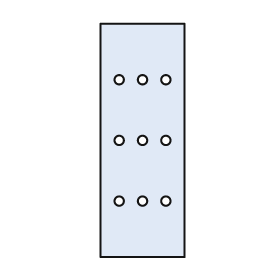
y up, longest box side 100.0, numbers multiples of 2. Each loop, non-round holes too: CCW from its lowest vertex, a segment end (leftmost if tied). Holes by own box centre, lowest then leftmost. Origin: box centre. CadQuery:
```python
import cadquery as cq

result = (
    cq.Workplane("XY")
    .moveTo(-18.0, -50.0)
    .lineTo(18.0, -50.0)
    .lineTo(18.0, 50.0)
    .lineTo(-18.0, 50.0)
    .close()
    .moveTo(-10.0, -26.0)
    .circle(2.0)
    .moveTo(0.0, -26.0)
    .circle(2.0)
    .moveTo(10.0, -26.0)
    .circle(2.0)
    .moveTo(-10.0, 0.0)
    .circle(2.0)
    .moveTo(0.0, 0.0)
    .circle(2.0)
    .moveTo(10.0, 0.0)
    .circle(2.0)
    .moveTo(-10.0, 26.0)
    .circle(2.0)
    .moveTo(0.0, 26.0)
    .circle(2.0)
    .moveTo(10.0, 26.0)
    .circle(2.0)
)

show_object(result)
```